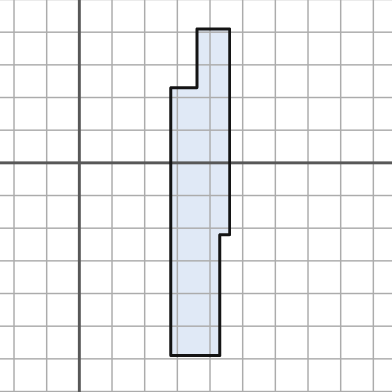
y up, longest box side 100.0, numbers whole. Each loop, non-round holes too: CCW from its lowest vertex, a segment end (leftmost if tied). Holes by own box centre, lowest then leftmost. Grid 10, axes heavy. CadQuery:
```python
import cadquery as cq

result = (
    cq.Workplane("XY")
    .moveTo(28.0, -59.0)
    .lineTo(43.0, -59.0)
    .lineTo(43.0, -22.0)
    .lineTo(46.0, -22.0)
    .lineTo(46.0, 41.0)
    .lineTo(36.0, 41.0)
    .lineTo(36.0, 23.0)
    .lineTo(28.0, 23.0)
    .close()
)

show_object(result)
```